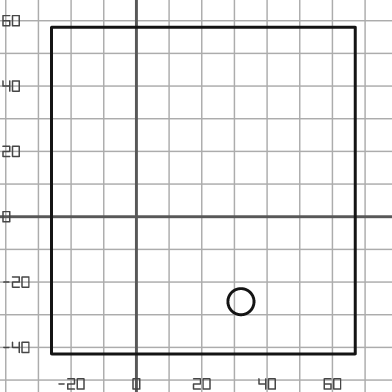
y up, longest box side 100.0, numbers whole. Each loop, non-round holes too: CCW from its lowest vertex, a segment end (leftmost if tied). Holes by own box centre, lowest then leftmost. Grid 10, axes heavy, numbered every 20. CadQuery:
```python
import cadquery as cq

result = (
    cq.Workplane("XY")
    .moveTo(-26.0, -42.0)
    .lineTo(67.0, -42.0)
    .lineTo(67.0, 58.0)
    .lineTo(-26.0, 58.0)
    .close()
    .moveTo(32.0, -26.0)
    .circle(4.0)
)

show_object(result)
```